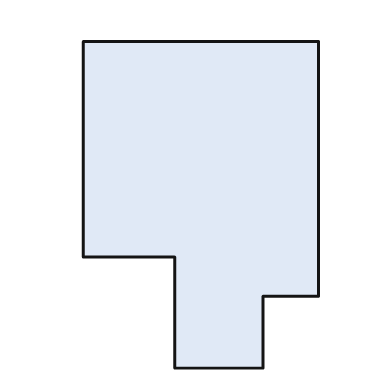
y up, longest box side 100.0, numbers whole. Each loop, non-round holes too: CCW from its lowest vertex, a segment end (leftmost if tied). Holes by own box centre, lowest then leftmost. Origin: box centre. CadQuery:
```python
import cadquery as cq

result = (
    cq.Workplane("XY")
    .moveTo(-8.0, -50.0)
    .lineTo(19.0, -50.0)
    .lineTo(19.0, -28.0)
    .lineTo(36.0, -28.0)
    .lineTo(36.0, 50.0)
    .lineTo(-36.0, 50.0)
    .lineTo(-36.0, -16.0)
    .lineTo(-8.0, -16.0)
    .close()
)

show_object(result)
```